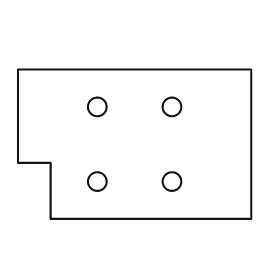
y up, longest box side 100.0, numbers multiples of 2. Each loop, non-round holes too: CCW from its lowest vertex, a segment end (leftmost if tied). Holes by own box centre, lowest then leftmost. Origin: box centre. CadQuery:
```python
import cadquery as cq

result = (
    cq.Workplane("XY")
    .moveTo(-36.0, -32.0)
    .lineTo(50.0, -32.0)
    .lineTo(50.0, 32.0)
    .lineTo(-50.0, 32.0)
    .lineTo(-50.0, -8.0)
    .lineTo(-36.0, -8.0)
    .close()
    .moveTo(-16.0, -16.0)
    .circle(4.0)
    .moveTo(16.0, -16.0)
    .circle(4.0)
    .moveTo(-16.0, 16.0)
    .circle(4.0)
    .moveTo(16.0, 16.0)
    .circle(4.0)
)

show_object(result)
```